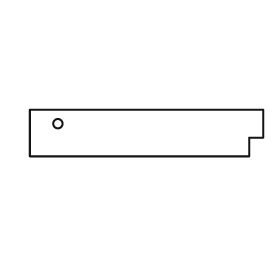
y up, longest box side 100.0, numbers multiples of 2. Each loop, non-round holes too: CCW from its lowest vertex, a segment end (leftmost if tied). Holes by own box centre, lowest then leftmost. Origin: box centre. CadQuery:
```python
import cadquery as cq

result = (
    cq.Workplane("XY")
    .moveTo(-50.0, -10.0)
    .lineTo(44.0, -10.0)
    .lineTo(44.0, -2.0)
    .lineTo(50.0, -2.0)
    .lineTo(50.0, 10.0)
    .lineTo(-50.0, 10.0)
    .close()
    .moveTo(-38.0, 4.0)
    .circle(2.0)
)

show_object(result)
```